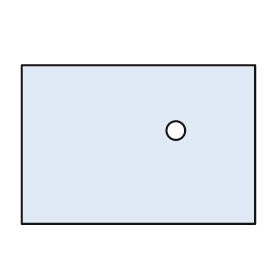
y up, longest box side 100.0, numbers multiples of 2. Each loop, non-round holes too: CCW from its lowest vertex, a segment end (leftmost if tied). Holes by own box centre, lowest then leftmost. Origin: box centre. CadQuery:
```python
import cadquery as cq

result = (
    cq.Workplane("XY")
    .moveTo(-50.0, -34.0)
    .lineTo(50.0, -34.0)
    .lineTo(50.0, 34.0)
    .lineTo(-50.0, 34.0)
    .close()
    .moveTo(16.0, 6.0)
    .circle(4.0)
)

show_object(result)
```